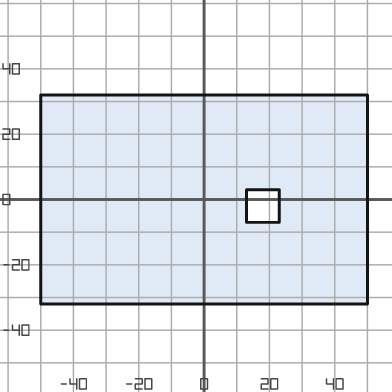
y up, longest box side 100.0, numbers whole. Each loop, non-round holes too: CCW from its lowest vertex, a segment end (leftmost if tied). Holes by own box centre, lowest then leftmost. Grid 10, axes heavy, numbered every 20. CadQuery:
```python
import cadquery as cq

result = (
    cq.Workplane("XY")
    .moveTo(-50.0, -32.0)
    .lineTo(50.0, -32.0)
    .lineTo(50.0, 32.0)
    .lineTo(-50.0, 32.0)
    .close()
    .moveTo(13.0, -7.0)
    .lineTo(23.0, -7.0)
    .lineTo(23.0, 3.0)
    .lineTo(13.0, 3.0)
    .close()
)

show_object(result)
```